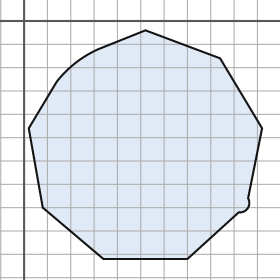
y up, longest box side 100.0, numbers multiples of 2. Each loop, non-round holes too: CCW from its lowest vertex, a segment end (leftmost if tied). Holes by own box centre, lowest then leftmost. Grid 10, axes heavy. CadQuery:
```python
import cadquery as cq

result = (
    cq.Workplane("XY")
    .moveTo(34.0, -102.0)
    .lineTo(70.0, -102.0)
    .lineTo(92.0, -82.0)
    .threePointArc((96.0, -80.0), (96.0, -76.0))
    .lineTo(102.0, -46.0)
    .lineTo(84.0, -16.0)
    .lineTo(52.0, -4.0)
    .lineTo(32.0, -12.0)
    .threePointArc((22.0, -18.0), (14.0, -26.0))
    .lineTo(2.0, -46.0)
    .lineTo(8.0, -80.0)
    .close()
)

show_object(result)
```